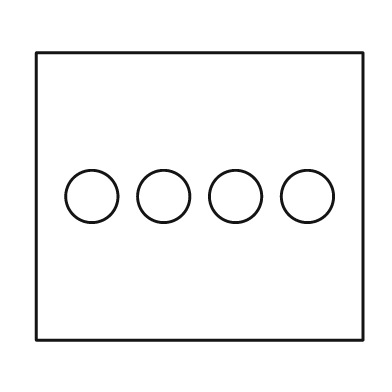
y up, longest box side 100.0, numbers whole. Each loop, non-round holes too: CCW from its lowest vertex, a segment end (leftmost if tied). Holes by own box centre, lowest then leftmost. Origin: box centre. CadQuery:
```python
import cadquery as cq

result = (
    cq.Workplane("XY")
    .moveTo(-50.0, -44.0)
    .lineTo(50.0, -44.0)
    .lineTo(50.0, 44.0)
    .lineTo(-50.0, 44.0)
    .close()
    .moveTo(-33.0, 0.0)
    .circle(8.0)
    .moveTo(-11.0, 0.0)
    .circle(8.0)
    .moveTo(11.0, 0.0)
    .circle(8.0)
    .moveTo(33.0, 0.0)
    .circle(8.0)
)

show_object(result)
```